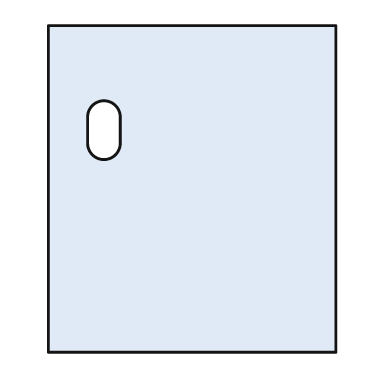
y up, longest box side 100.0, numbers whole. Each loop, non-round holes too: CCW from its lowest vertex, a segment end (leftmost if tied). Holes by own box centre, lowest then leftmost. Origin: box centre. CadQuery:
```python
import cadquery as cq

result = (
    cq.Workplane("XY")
    .moveTo(-44.0, -50.0)
    .lineTo(44.0, -50.0)
    .lineTo(44.0, 50.0)
    .lineTo(-44.0, 50.0)
    .close()
    .moveTo(-32.0, 14.0)
    .threePointArc((-27.0, 9.0), (-22.0, 14.0))
    .lineTo(-22.0, 22.0)
    .threePointArc((-27.0, 27.0), (-32.0, 22.0))
    .close()
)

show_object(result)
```